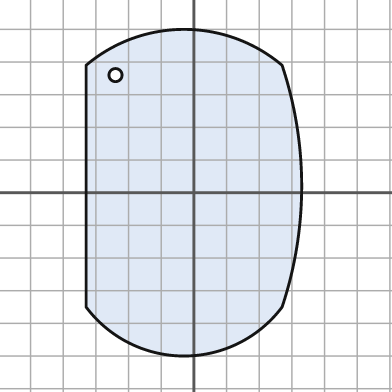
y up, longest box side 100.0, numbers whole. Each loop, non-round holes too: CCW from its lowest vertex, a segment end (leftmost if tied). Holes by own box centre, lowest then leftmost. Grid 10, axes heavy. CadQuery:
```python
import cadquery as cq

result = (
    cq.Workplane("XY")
    .moveTo(-33.0, -35.0)
    .threePointArc((-3.0, -50.0), (27.0, -35.0))
    .threePointArc((33.0, 2.0), (27.0, 39.0))
    .threePointArc((-3.0, 50.0), (-33.0, 39.0))
    .close()
    .moveTo(-24.0, 36.0)
    .circle(2.0)
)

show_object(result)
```